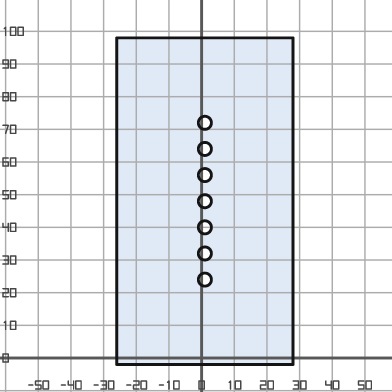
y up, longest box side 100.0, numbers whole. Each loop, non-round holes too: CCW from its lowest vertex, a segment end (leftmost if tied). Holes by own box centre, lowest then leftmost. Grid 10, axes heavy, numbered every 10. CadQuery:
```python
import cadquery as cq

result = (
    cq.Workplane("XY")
    .moveTo(-26.0, -2.0)
    .lineTo(28.0, -2.0)
    .lineTo(28.0, 98.0)
    .lineTo(-26.0, 98.0)
    .close()
    .moveTo(1.0, 24.0)
    .circle(2.0)
    .moveTo(1.0, 32.0)
    .circle(2.0)
    .moveTo(1.0, 40.0)
    .circle(2.0)
    .moveTo(1.0, 48.0)
    .circle(2.0)
    .moveTo(1.0, 56.0)
    .circle(2.0)
    .moveTo(1.0, 64.0)
    .circle(2.0)
    .moveTo(1.0, 72.0)
    .circle(2.0)
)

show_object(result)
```